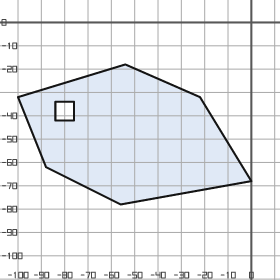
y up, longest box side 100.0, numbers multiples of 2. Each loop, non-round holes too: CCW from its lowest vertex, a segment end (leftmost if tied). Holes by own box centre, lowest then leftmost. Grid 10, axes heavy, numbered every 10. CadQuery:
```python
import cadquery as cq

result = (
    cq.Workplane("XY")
    .moveTo(-56.0, -78.0)
    .lineTo(0.0, -68.0)
    .lineTo(-22.0, -32.0)
    .lineTo(-54.0, -18.0)
    .lineTo(-100.0, -32.0)
    .lineTo(-88.0, -62.0)
    .close()
    .moveTo(-84.0, -42.0)
    .lineTo(-76.0, -42.0)
    .lineTo(-76.0, -34.0)
    .lineTo(-84.0, -34.0)
    .close()
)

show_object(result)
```